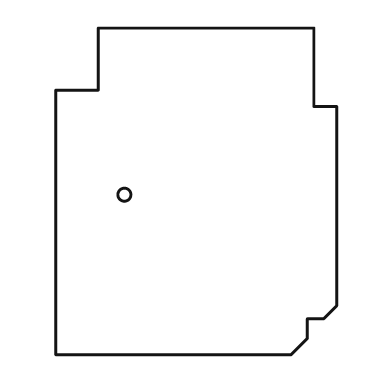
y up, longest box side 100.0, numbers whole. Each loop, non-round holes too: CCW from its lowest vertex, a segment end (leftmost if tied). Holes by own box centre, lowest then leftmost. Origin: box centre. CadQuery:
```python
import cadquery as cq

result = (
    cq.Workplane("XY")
    .moveTo(-43.0, -50.0)
    .lineTo(29.0, -50.0)
    .lineTo(34.0, -45.0)
    .lineTo(34.0, -39.0)
    .lineTo(39.0, -39.0)
    .lineTo(43.0, -35.0)
    .lineTo(43.0, 26.0)
    .lineTo(36.0, 26.0)
    .lineTo(36.0, 50.0)
    .lineTo(-30.0, 50.0)
    .lineTo(-30.0, 31.0)
    .lineTo(-43.0, 31.0)
    .close()
    .moveTo(-22.0, -1.0)
    .circle(2.0)
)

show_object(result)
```